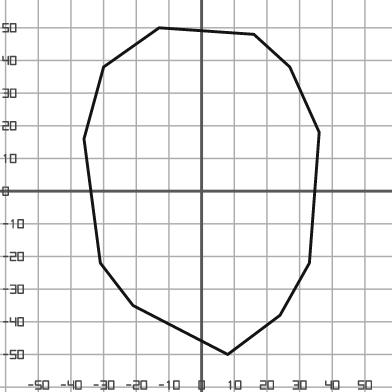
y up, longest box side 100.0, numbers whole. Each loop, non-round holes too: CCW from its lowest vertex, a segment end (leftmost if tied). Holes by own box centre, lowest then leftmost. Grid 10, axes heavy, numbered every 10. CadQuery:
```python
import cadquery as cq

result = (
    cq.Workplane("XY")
    .moveTo(8.0, -50.0)
    .lineTo(24.0, -38.0)
    .lineTo(33.0, -22.0)
    .lineTo(36.0, 18.0)
    .lineTo(27.0, 38.0)
    .lineTo(16.0, 48.0)
    .lineTo(-13.0, 50.0)
    .lineTo(-30.0, 38.0)
    .lineTo(-36.0, 16.0)
    .lineTo(-31.0, -22.0)
    .lineTo(-21.0, -35.0)
    .close()
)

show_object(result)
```